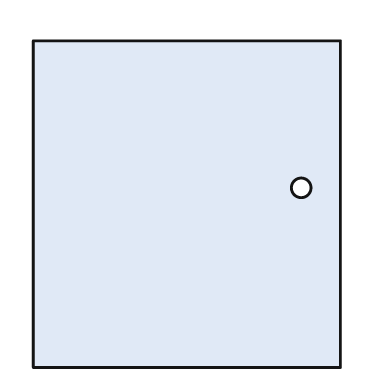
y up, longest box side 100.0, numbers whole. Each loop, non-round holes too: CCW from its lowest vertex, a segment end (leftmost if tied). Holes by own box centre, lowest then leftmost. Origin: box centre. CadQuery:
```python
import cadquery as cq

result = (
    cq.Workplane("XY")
    .moveTo(-47.0, -50.0)
    .lineTo(47.0, -50.0)
    .lineTo(47.0, 50.0)
    .lineTo(-47.0, 50.0)
    .close()
    .moveTo(35.0, 5.0)
    .circle(3.0)
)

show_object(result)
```